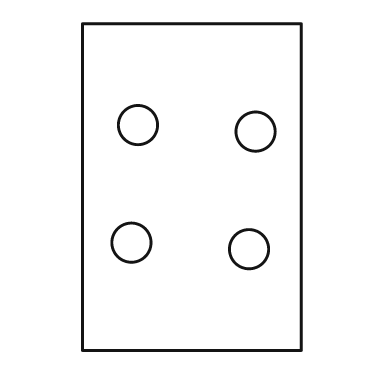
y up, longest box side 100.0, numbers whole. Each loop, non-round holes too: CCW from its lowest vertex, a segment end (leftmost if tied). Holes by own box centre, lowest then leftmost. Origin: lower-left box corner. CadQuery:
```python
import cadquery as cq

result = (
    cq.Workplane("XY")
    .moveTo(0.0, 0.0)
    .lineTo(67.0, 0.0)
    .lineTo(67.0, 100.0)
    .lineTo(0.0, 100.0)
    .close()
    .moveTo(51.0, 31.0)
    .circle(6.0)
    .moveTo(15.0, 33.0)
    .circle(6.0)
    .moveTo(53.0, 67.0)
    .circle(6.0)
    .moveTo(17.0, 69.0)
    .circle(6.0)
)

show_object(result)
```